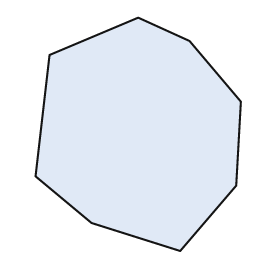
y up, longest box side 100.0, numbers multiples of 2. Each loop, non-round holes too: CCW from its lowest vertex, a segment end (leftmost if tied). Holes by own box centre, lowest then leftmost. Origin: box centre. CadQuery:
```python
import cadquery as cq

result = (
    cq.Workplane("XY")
    .moveTo(18.0, -50.0)
    .lineTo(42.0, -22.0)
    .lineTo(44.0, 14.0)
    .lineTo(22.0, 40.0)
    .lineTo(0.0, 50.0)
    .lineTo(-38.0, 34.0)
    .lineTo(-44.0, -18.0)
    .lineTo(-20.0, -38.0)
    .close()
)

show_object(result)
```